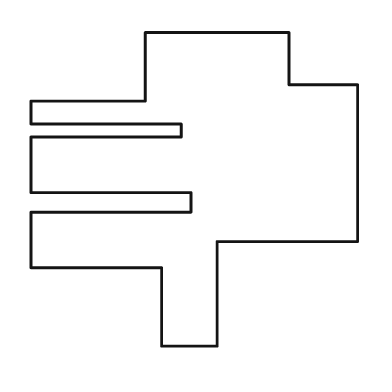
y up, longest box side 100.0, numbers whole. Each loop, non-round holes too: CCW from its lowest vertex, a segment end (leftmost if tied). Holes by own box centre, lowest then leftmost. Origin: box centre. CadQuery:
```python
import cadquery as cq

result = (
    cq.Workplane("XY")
    .moveTo(-10.0, -48.0)
    .lineTo(7.0, -48.0)
    .lineTo(7.0, -16.0)
    .lineTo(50.0, -16.0)
    .lineTo(50.0, 32.0)
    .lineTo(29.0, 32.0)
    .lineTo(29.0, 48.0)
    .lineTo(-15.0, 48.0)
    .lineTo(-15.0, 27.0)
    .lineTo(-50.0, 27.0)
    .lineTo(-50.0, 20.0)
    .lineTo(-4.0, 20.0)
    .lineTo(-4.0, 16.0)
    .lineTo(-50.0, 16.0)
    .lineTo(-50.0, -1.0)
    .lineTo(-1.0, -1.0)
    .lineTo(-1.0, -7.0)
    .lineTo(-50.0, -7.0)
    .lineTo(-50.0, -24.0)
    .lineTo(-10.0, -24.0)
    .close()
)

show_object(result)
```